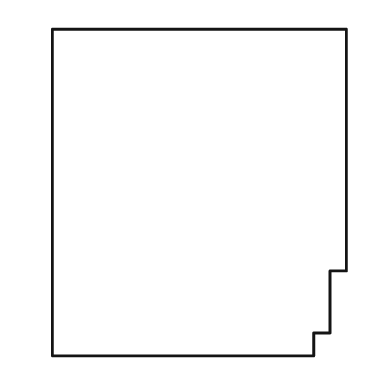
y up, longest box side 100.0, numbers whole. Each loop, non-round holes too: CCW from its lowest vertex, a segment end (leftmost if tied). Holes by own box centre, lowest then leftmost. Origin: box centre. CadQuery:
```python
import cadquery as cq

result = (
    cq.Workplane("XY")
    .moveTo(-45.0, -50.0)
    .lineTo(35.0, -50.0)
    .lineTo(35.0, -43.0)
    .lineTo(40.0, -43.0)
    .lineTo(40.0, -24.0)
    .lineTo(45.0, -24.0)
    .lineTo(45.0, 50.0)
    .lineTo(-45.0, 50.0)
    .close()
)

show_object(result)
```